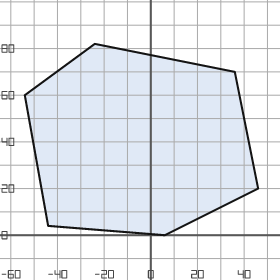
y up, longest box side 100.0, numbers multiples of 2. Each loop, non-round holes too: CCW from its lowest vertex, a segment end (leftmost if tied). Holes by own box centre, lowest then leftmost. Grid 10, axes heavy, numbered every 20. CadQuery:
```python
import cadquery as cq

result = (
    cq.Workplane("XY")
    .moveTo(6.0, 0.0)
    .lineTo(46.0, 20.0)
    .lineTo(36.0, 70.0)
    .lineTo(-24.0, 82.0)
    .lineTo(-54.0, 60.0)
    .lineTo(-44.0, 4.0)
    .close()
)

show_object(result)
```